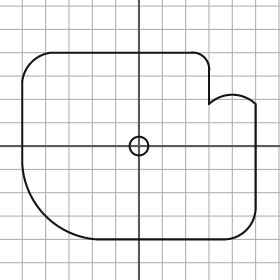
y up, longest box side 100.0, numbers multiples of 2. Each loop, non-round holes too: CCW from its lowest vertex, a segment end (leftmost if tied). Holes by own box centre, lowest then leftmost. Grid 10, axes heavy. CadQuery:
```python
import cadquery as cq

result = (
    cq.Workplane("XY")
    .moveTo(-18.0, -40.0)
    .lineTo(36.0, -40.0)
    .threePointArc((46.0, -36.0), (50.0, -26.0))
    .lineTo(50.0, 18.0)
    .threePointArc((40.0, 22.0), (30.0, 18.0))
    .lineTo(30.0, 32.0)
    .threePointArc((28.0, 38.0), (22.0, 40.0))
    .lineTo(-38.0, 40.0)
    .threePointArc((-46.0, 36.0), (-50.0, 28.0))
    .lineTo(-50.0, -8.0)
    .threePointArc((-40.0, -30.0), (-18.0, -40.0))
    .close()
    .moveTo(0.0, 0.0)
    .circle(4.0)
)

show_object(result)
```